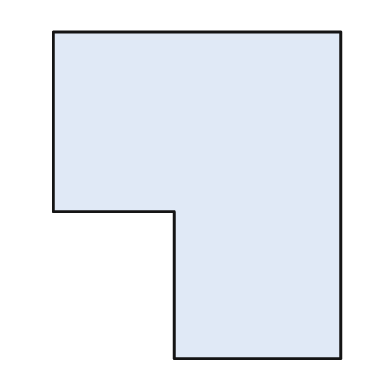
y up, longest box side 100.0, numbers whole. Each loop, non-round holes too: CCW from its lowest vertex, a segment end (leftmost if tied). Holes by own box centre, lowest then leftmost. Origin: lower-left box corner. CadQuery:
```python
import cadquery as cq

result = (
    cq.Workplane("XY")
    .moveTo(37.0, 0.0)
    .lineTo(88.0, 0.0)
    .lineTo(88.0, 100.0)
    .lineTo(0.0, 100.0)
    .lineTo(0.0, 45.0)
    .lineTo(37.0, 45.0)
    .close()
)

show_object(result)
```